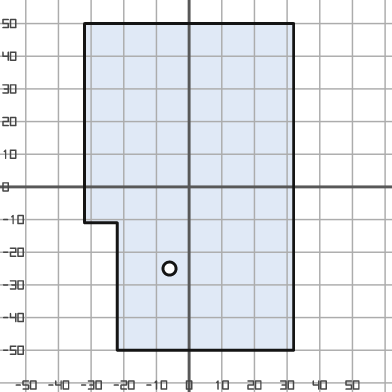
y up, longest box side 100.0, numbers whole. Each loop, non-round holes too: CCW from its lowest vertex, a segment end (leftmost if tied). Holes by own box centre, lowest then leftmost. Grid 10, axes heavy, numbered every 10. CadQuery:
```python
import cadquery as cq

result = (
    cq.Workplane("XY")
    .moveTo(-22.0, -50.0)
    .lineTo(32.0, -50.0)
    .lineTo(32.0, 50.0)
    .lineTo(-32.0, 50.0)
    .lineTo(-32.0, -11.0)
    .lineTo(-22.0, -11.0)
    .close()
    .moveTo(-6.0, -25.0)
    .circle(2.0)
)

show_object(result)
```